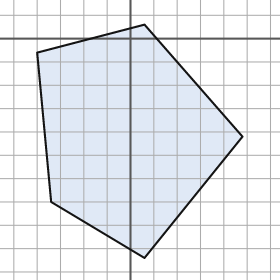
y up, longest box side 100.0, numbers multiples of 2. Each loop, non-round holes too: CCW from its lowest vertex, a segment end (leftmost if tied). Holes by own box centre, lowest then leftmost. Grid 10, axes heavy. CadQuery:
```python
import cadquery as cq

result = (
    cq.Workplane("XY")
    .moveTo(6.0, -94.0)
    .lineTo(48.0, -42.0)
    .lineTo(6.0, 6.0)
    .lineTo(-40.0, -6.0)
    .lineTo(-34.0, -70.0)
    .close()
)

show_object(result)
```